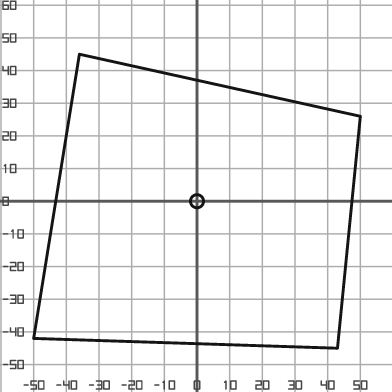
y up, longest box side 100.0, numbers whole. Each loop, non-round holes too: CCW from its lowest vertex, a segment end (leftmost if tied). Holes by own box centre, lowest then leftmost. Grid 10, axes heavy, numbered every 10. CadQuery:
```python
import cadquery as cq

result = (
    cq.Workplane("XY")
    .moveTo(43.0, -45.0)
    .lineTo(50.0, 26.0)
    .lineTo(-36.0, 45.0)
    .lineTo(-50.0, -42.0)
    .close()
    .moveTo(0.0, 0.0)
    .circle(2.0)
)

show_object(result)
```